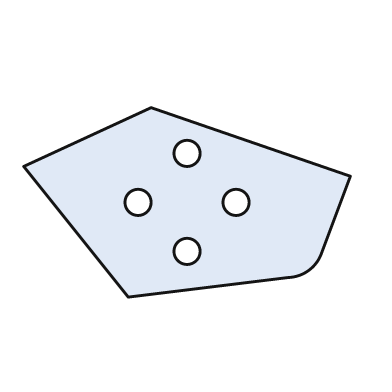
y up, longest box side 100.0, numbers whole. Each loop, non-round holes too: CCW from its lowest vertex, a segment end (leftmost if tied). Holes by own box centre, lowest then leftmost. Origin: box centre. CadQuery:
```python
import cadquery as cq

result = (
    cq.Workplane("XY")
    .moveTo(-18.0, -29.0)
    .lineTo(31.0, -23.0)
    .threePointArc((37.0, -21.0), (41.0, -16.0))
    .lineTo(50.0, 8.0)
    .lineTo(-11.0, 29.0)
    .lineTo(-50.0, 11.0)
    .close()
    .moveTo(0.0, -15.0)
    .circle(4.0)
    .moveTo(-15.0, 0.0)
    .circle(4.0)
    .moveTo(15.0, 0.0)
    .circle(4.0)
    .moveTo(0.0, 15.0)
    .circle(4.0)
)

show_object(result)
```